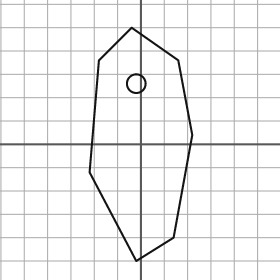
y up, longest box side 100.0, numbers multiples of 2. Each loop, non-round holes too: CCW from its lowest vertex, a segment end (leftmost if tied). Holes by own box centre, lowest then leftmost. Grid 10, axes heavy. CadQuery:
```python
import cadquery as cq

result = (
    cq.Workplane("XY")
    .moveTo(-2.0, -50.0)
    .lineTo(14.0, -40.0)
    .lineTo(22.0, 4.0)
    .lineTo(16.0, 36.0)
    .lineTo(-4.0, 50.0)
    .lineTo(-18.0, 36.0)
    .lineTo(-22.0, -12.0)
    .close()
    .moveTo(-2.0, 26.0)
    .circle(4.0)
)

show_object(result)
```